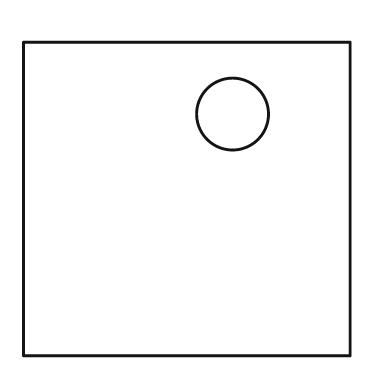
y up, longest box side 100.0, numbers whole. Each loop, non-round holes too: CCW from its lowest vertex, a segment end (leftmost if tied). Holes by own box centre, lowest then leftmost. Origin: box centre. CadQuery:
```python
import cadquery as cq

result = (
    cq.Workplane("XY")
    .moveTo(-50.0, -48.0)
    .lineTo(50.0, -48.0)
    .lineTo(50.0, 48.0)
    .lineTo(-50.0, 48.0)
    .close()
    .moveTo(14.0, 26.0)
    .circle(11.0)
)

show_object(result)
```